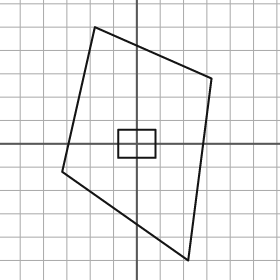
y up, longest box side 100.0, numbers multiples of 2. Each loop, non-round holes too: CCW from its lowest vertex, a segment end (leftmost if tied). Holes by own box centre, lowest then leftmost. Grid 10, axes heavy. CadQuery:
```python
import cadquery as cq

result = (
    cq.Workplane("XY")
    .moveTo(22.0, -50.0)
    .lineTo(32.0, 28.0)
    .lineTo(-18.0, 50.0)
    .lineTo(-32.0, -12.0)
    .close()
    .moveTo(-8.0, -6.0)
    .lineTo(8.0, -6.0)
    .lineTo(8.0, 6.0)
    .lineTo(-8.0, 6.0)
    .close()
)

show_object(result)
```